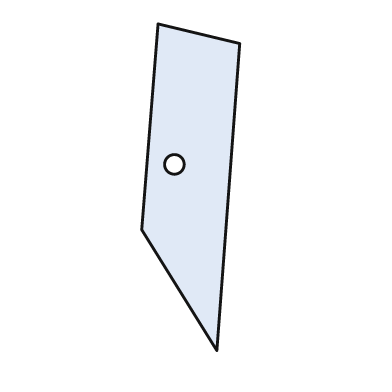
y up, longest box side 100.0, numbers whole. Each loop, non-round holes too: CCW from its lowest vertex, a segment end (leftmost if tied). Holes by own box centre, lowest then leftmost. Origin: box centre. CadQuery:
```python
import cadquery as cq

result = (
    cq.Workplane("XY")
    .moveTo(8.0, -50.0)
    .lineTo(15.0, 44.0)
    .lineTo(-10.0, 50.0)
    .lineTo(-15.0, -13.0)
    .close()
    .moveTo(-5.0, 7.0)
    .circle(3.0)
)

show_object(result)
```